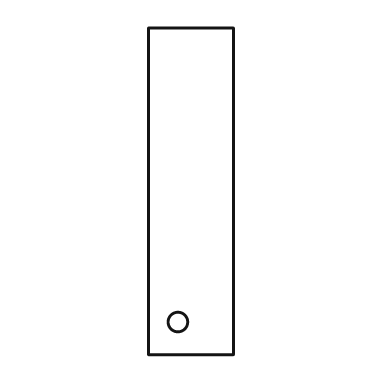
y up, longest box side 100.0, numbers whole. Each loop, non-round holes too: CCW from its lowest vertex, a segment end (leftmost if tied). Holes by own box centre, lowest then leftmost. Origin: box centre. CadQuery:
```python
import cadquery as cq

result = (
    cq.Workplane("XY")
    .moveTo(-13.0, -50.0)
    .lineTo(13.0, -50.0)
    .lineTo(13.0, 50.0)
    .lineTo(-13.0, 50.0)
    .close()
    .moveTo(-4.0, -40.0)
    .circle(3.0)
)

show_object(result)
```